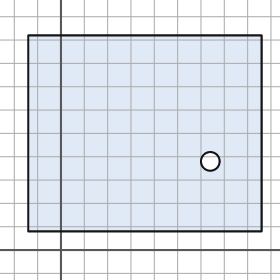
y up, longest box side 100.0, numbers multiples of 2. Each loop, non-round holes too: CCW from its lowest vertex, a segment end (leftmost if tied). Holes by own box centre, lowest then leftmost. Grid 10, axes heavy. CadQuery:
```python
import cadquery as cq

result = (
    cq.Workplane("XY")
    .moveTo(-14.0, 8.0)
    .lineTo(86.0, 8.0)
    .lineTo(86.0, 92.0)
    .lineTo(-14.0, 92.0)
    .close()
    .moveTo(64.0, 38.0)
    .circle(4.0)
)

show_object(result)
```